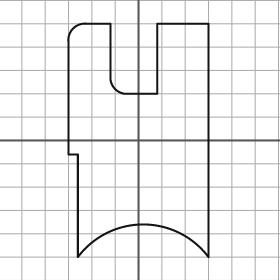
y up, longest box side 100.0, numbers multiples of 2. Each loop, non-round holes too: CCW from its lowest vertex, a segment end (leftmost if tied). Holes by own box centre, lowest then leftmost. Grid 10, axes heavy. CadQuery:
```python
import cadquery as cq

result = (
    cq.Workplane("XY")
    .moveTo(-26.0, -50.0)
    .threePointArc((2.0, -36.0), (30.0, -50.0))
    .lineTo(30.0, 50.0)
    .lineTo(8.0, 50.0)
    .lineTo(8.0, 20.0)
    .lineTo(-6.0, 20.0)
    .threePointArc((-10.0, 22.0), (-12.0, 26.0))
    .lineTo(-12.0, 50.0)
    .lineTo(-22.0, 50.0)
    .threePointArc((-28.0, 48.0), (-30.0, 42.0))
    .lineTo(-30.0, -6.0)
    .lineTo(-26.0, -6.0)
    .close()
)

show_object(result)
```